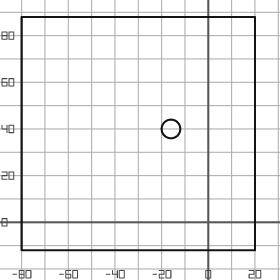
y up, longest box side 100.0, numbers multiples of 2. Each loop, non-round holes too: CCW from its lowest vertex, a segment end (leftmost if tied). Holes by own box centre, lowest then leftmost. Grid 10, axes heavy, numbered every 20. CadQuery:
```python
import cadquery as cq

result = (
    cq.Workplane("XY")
    .moveTo(-80.0, -12.0)
    .lineTo(20.0, -12.0)
    .lineTo(20.0, 88.0)
    .lineTo(-80.0, 88.0)
    .close()
    .moveTo(-16.0, 40.0)
    .circle(4.0)
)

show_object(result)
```